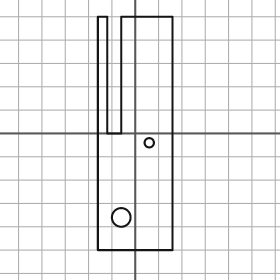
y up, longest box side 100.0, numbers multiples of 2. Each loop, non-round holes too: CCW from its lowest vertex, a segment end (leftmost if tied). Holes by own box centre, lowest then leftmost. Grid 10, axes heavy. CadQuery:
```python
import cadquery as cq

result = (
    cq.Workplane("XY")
    .moveTo(-16.0, -50.0)
    .lineTo(16.0, -50.0)
    .lineTo(16.0, 50.0)
    .lineTo(-6.0, 50.0)
    .lineTo(-6.0, 0.0)
    .lineTo(-12.0, 0.0)
    .lineTo(-12.0, 50.0)
    .lineTo(-16.0, 50.0)
    .close()
    .moveTo(-6.0, -36.0)
    .circle(4.0)
    .moveTo(6.0, -4.0)
    .circle(2.0)
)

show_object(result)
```